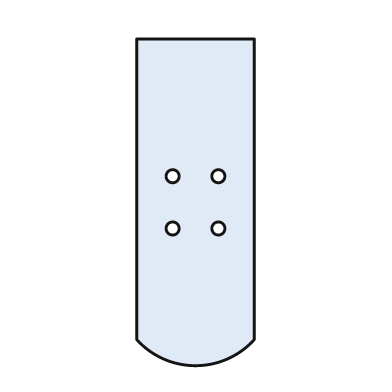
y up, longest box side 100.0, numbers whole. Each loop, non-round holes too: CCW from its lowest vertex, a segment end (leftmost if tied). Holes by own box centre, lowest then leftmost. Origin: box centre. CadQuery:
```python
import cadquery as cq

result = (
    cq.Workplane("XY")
    .moveTo(-18.0, -42.0)
    .threePointArc((0.0, -50.0), (18.0, -42.0))
    .lineTo(18.0, 50.0)
    .lineTo(-18.0, 50.0)
    .close()
    .moveTo(-7.0, -8.0)
    .circle(2.0)
    .moveTo(7.0, -8.0)
    .circle(2.0)
    .moveTo(-7.0, 8.0)
    .circle(2.0)
    .moveTo(7.0, 8.0)
    .circle(2.0)
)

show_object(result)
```